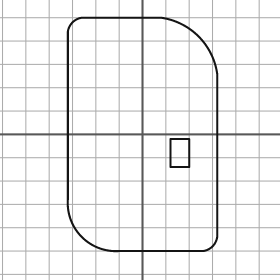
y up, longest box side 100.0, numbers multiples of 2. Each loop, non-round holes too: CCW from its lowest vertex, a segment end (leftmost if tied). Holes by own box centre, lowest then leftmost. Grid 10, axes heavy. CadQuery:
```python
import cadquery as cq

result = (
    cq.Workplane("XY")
    .moveTo(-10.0, -50.0)
    .lineTo(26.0, -50.0)
    .threePointArc((30.0, -48.0), (32.0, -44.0))
    .lineTo(32.0, 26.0)
    .threePointArc((24.0, 42.0), (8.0, 50.0))
    .lineTo(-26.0, 50.0)
    .threePointArc((-30.0, 48.0), (-32.0, 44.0))
    .lineTo(-32.0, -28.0)
    .threePointArc((-26.0, -44.0), (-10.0, -50.0))
    .close()
    .moveTo(12.0, -14.0)
    .lineTo(20.0, -14.0)
    .lineTo(20.0, -2.0)
    .lineTo(12.0, -2.0)
    .close()
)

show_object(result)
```